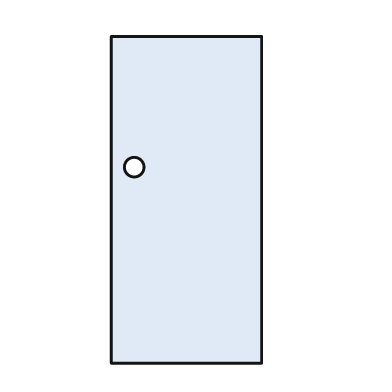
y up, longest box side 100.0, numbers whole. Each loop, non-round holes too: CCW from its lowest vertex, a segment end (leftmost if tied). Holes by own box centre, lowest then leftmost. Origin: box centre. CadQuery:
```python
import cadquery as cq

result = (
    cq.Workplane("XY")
    .moveTo(-23.0, -50.0)
    .lineTo(23.0, -50.0)
    .lineTo(23.0, 50.0)
    .lineTo(-23.0, 50.0)
    .close()
    .moveTo(-16.0, 10.0)
    .circle(3.0)
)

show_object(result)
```